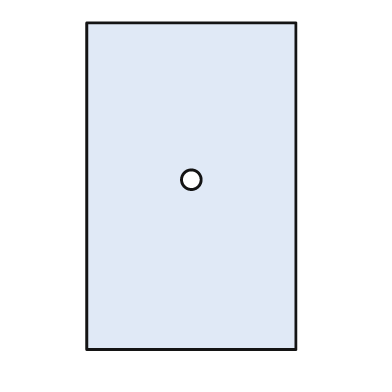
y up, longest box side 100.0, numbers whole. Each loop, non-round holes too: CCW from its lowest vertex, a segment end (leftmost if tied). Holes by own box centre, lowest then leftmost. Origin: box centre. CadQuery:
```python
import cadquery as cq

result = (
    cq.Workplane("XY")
    .moveTo(-32.0, -50.0)
    .lineTo(32.0, -50.0)
    .lineTo(32.0, 50.0)
    .lineTo(-32.0, 50.0)
    .close()
    .moveTo(0.0, 2.0)
    .circle(3.0)
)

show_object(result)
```